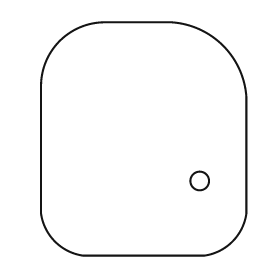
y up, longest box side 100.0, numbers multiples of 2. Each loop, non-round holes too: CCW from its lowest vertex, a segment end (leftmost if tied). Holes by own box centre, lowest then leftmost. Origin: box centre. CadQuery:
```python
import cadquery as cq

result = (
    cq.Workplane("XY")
    .moveTo(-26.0, -50.0)
    .lineTo(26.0, -50.0)
    .threePointArc((38.0, -44.0), (44.0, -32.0))
    .lineTo(44.0, 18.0)
    .threePointArc((34.0, 40.0), (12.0, 50.0))
    .lineTo(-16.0, 50.0)
    .threePointArc((-36.0, 42.0), (-44.0, 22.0))
    .lineTo(-44.0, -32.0)
    .threePointArc((-38.0, -44.0), (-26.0, -50.0))
    .close()
    .moveTo(24.0, -18.0)
    .circle(4.0)
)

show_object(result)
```